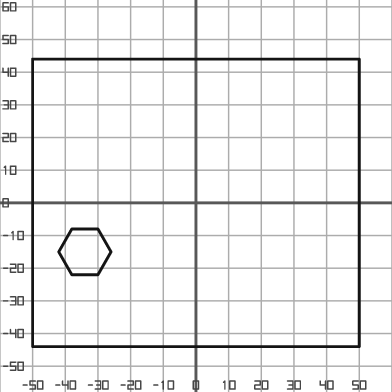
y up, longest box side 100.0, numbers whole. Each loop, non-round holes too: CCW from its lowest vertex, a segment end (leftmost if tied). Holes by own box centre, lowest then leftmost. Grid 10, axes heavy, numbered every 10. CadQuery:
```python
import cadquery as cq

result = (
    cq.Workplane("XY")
    .moveTo(-50.0, -44.0)
    .lineTo(50.0, -44.0)
    .lineTo(50.0, 44.0)
    .lineTo(-50.0, 44.0)
    .close()
    .moveTo(-38.0, -22.0)
    .lineTo(-30.0, -22.0)
    .lineTo(-26.0, -15.0)
    .lineTo(-30.0, -8.0)
    .lineTo(-38.0, -8.0)
    .lineTo(-42.0, -15.0)
    .close()
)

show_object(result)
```